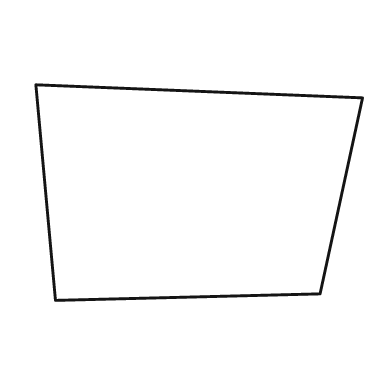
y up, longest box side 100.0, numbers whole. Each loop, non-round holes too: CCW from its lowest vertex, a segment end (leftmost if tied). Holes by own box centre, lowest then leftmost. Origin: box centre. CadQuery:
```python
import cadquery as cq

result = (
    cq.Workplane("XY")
    .moveTo(-44.0, -33.0)
    .lineTo(37.0, -31.0)
    .lineTo(50.0, 29.0)
    .lineTo(-50.0, 33.0)
    .close()
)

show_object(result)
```